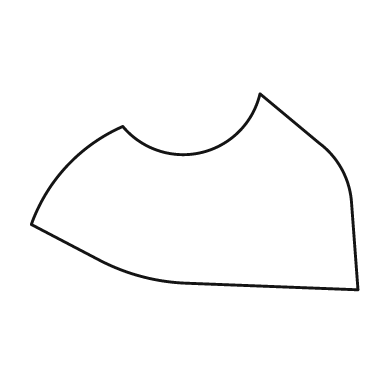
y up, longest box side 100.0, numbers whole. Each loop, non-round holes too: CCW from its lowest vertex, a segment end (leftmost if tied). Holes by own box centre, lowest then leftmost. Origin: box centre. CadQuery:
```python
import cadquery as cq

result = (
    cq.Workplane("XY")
    .moveTo(50.0, -30.0)
    .lineTo(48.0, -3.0)
    .threePointArc((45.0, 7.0), (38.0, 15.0))
    .lineTo(20.0, 30.0)
    .threePointArc((2.0, 12.0), (-22.0, 20.0))
    .threePointArc((-39.0, 8.0), (-50.0, -10.0))
    .lineTo(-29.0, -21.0)
    .threePointArc((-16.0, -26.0), (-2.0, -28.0))
    .close()
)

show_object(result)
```